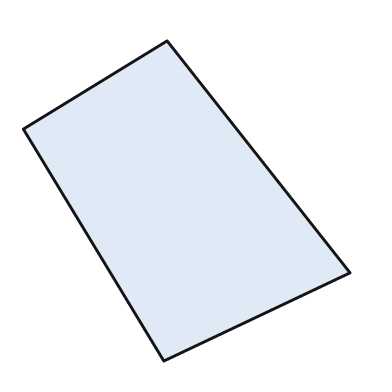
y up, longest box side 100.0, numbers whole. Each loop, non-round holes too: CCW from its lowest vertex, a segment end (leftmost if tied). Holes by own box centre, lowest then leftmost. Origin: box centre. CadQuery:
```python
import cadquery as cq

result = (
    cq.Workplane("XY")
    .moveTo(-7.0, -49.0)
    .lineTo(50.0, -22.0)
    .lineTo(-6.0, 49.0)
    .lineTo(-50.0, 22.0)
    .close()
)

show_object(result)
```